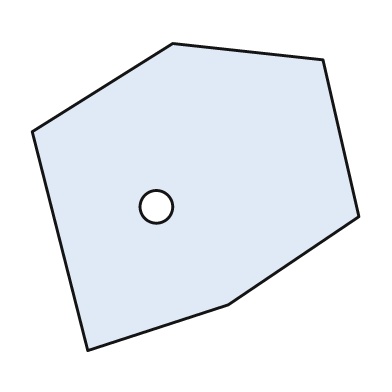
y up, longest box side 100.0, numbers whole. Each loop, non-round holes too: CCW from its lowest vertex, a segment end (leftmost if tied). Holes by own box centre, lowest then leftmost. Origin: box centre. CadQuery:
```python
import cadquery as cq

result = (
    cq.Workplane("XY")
    .moveTo(-33.0, -47.0)
    .lineTo(10.0, -33.0)
    .lineTo(50.0, -6.0)
    .lineTo(39.0, 42.0)
    .lineTo(-7.0, 47.0)
    .lineTo(-50.0, 20.0)
    .close()
    .moveTo(-12.0, -3.0)
    .circle(5.0)
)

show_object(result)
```